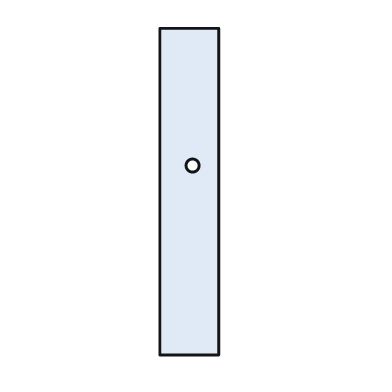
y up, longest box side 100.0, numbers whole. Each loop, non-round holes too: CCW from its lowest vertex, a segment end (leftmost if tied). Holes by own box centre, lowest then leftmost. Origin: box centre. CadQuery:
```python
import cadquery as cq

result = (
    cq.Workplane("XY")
    .moveTo(-9.0, -50.0)
    .lineTo(9.0, -50.0)
    .lineTo(9.0, 50.0)
    .lineTo(-9.0, 50.0)
    .close()
    .moveTo(1.0, 8.0)
    .circle(2.0)
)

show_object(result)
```